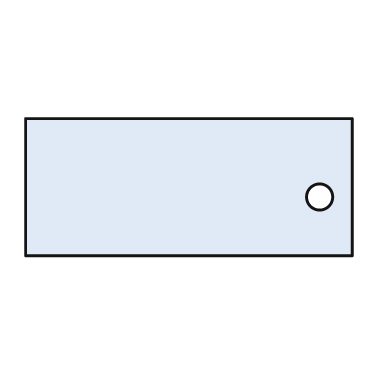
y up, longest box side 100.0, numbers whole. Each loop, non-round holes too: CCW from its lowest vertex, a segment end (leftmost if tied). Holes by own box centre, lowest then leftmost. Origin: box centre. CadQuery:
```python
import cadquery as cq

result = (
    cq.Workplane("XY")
    .moveTo(-50.0, -21.0)
    .lineTo(50.0, -21.0)
    .lineTo(50.0, 21.0)
    .lineTo(-50.0, 21.0)
    .close()
    .moveTo(40.0, -3.0)
    .circle(4.0)
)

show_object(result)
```